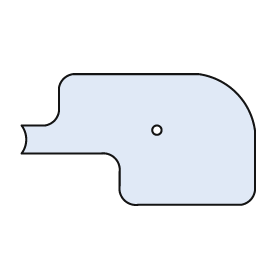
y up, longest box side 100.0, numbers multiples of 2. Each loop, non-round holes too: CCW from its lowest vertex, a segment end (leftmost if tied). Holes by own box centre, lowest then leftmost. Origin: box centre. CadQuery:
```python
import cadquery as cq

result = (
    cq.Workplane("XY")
    .moveTo(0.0, -28.0)
    .lineTo(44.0, -28.0)
    .threePointArc((48.0, -26.0), (50.0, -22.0))
    .lineTo(50.0, 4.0)
    .threePointArc((42.0, 20.0), (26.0, 28.0))
    .lineTo(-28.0, 28.0)
    .threePointArc((-32.0, 26.0), (-34.0, 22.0))
    .lineTo(-34.0, 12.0)
    .threePointArc((-36.0, 8.0), (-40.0, 6.0))
    .lineTo(-50.0, 6.0)
    .threePointArc((-48.0, 0.0), (-50.0, -6.0))
    .lineTo(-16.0, -6.0)
    .threePointArc((-10.0, -8.0), (-8.0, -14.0))
    .lineTo(-8.0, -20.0)
    .threePointArc((-6.0, -26.0), (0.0, -28.0))
    .close()
    .moveTo(8.0, 4.0)
    .circle(2.0)
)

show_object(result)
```